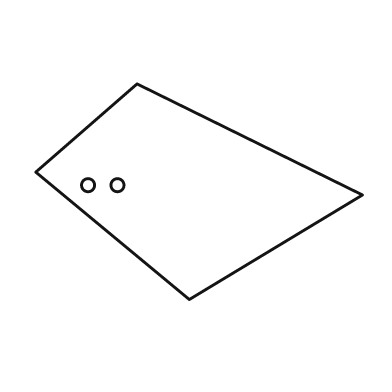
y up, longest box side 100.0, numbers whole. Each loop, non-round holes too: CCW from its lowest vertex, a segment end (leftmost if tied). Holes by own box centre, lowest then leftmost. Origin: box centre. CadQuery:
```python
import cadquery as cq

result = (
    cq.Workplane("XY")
    .moveTo(-3.0, -33.0)
    .lineTo(50.0, -1.0)
    .lineTo(-19.0, 33.0)
    .lineTo(-50.0, 6.0)
    .close()
    .moveTo(-34.0, 2.0)
    .circle(2.0)
    .moveTo(-25.0, 2.0)
    .circle(2.0)
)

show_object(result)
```